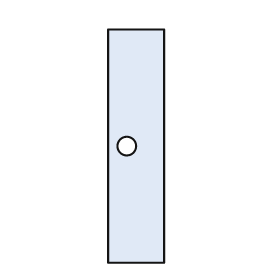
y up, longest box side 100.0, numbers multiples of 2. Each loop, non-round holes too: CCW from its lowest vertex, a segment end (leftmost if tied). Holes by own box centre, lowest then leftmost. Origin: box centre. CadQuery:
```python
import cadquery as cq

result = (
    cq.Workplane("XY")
    .moveTo(-12.0, -50.0)
    .lineTo(12.0, -50.0)
    .lineTo(12.0, 50.0)
    .lineTo(-12.0, 50.0)
    .close()
    .moveTo(-4.0, 0.0)
    .circle(4.0)
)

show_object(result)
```